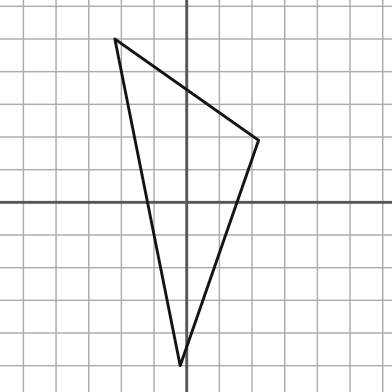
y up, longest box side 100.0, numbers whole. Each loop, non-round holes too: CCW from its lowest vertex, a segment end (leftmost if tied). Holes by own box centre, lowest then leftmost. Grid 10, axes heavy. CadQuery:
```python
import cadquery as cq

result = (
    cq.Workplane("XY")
    .moveTo(-2.0, -50.0)
    .lineTo(22.0, 19.0)
    .lineTo(-22.0, 50.0)
    .close()
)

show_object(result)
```